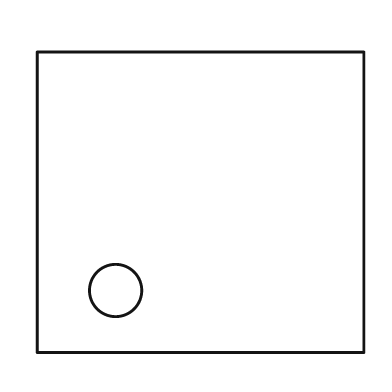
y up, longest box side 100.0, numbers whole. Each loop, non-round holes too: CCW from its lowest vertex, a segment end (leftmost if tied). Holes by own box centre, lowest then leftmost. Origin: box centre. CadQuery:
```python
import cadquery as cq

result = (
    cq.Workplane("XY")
    .moveTo(-50.0, -46.0)
    .lineTo(50.0, -46.0)
    .lineTo(50.0, 46.0)
    .lineTo(-50.0, 46.0)
    .close()
    .moveTo(-26.0, -27.0)
    .circle(8.0)
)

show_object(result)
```